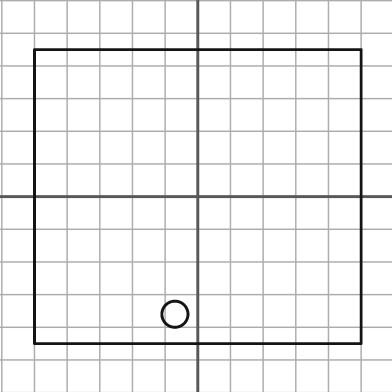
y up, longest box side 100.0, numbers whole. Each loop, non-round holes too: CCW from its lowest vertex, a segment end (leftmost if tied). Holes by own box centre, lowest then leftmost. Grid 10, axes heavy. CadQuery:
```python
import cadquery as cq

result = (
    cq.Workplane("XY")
    .moveTo(-50.0, -45.0)
    .lineTo(50.0, -45.0)
    .lineTo(50.0, 45.0)
    .lineTo(-50.0, 45.0)
    .close()
    .moveTo(-7.0, -36.0)
    .circle(4.0)
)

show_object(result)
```